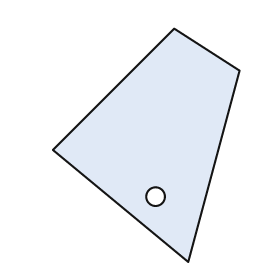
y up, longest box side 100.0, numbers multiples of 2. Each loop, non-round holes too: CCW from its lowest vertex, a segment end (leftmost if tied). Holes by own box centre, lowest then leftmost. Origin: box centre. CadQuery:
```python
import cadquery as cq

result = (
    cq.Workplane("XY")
    .moveTo(18.0, -50.0)
    .lineTo(40.0, 32.0)
    .lineTo(12.0, 50.0)
    .lineTo(-40.0, -2.0)
    .close()
    .moveTo(4.0, -22.0)
    .circle(4.0)
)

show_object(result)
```